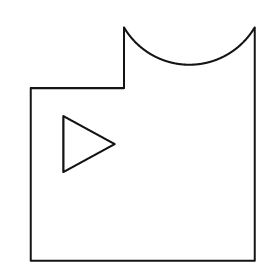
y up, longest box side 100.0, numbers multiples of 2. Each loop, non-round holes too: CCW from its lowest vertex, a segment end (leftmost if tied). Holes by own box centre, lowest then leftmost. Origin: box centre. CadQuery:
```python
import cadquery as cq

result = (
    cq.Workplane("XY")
    .moveTo(-48.0, -50.0)
    .lineTo(48.0, -50.0)
    .lineTo(48.0, 50.0)
    .threePointArc((20.0, 34.0), (-8.0, 50.0))
    .lineTo(-8.0, 24.0)
    .lineTo(-48.0, 24.0)
    .close()
    .moveTo(-34.0, -12.0)
    .lineTo(-12.0, 0.0)
    .lineTo(-34.0, 12.0)
    .close()
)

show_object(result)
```